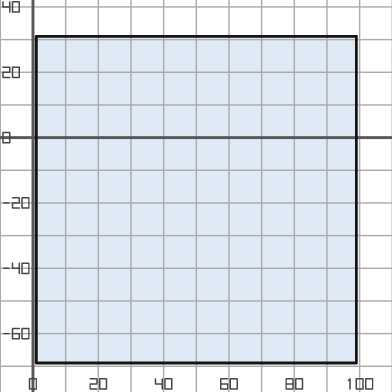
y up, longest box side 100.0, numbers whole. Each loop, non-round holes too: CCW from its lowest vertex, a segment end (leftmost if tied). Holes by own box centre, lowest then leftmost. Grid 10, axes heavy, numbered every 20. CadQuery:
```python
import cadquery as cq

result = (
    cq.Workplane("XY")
    .moveTo(1.0, -69.0)
    .lineTo(99.0, -69.0)
    .lineTo(99.0, 31.0)
    .lineTo(1.0, 31.0)
    .close()
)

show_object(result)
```